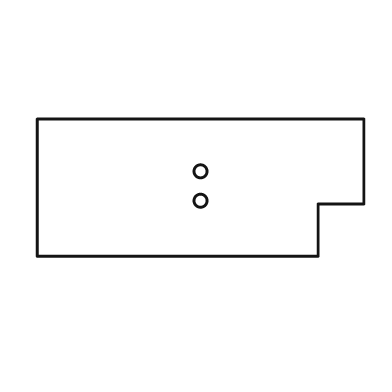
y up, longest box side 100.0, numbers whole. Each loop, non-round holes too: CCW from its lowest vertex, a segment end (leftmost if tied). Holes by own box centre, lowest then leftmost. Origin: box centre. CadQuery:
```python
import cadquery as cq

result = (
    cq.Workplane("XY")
    .moveTo(-50.0, -21.0)
    .lineTo(36.0, -21.0)
    .lineTo(36.0, -5.0)
    .lineTo(50.0, -5.0)
    .lineTo(50.0, 21.0)
    .lineTo(-50.0, 21.0)
    .close()
    .moveTo(0.0, -4.0)
    .circle(2.0)
    .moveTo(0.0, 5.0)
    .circle(2.0)
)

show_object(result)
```